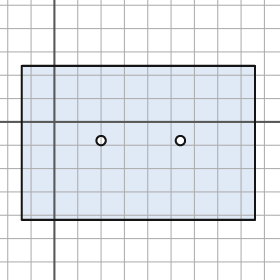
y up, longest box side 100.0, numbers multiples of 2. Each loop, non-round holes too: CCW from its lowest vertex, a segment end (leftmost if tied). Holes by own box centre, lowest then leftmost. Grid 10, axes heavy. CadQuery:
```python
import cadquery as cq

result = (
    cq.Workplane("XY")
    .moveTo(-14.0, -42.0)
    .lineTo(86.0, -42.0)
    .lineTo(86.0, 24.0)
    .lineTo(-14.0, 24.0)
    .close()
    .moveTo(20.0, -8.0)
    .circle(2.0)
    .moveTo(54.0, -8.0)
    .circle(2.0)
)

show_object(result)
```